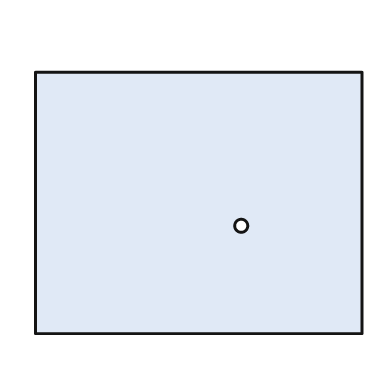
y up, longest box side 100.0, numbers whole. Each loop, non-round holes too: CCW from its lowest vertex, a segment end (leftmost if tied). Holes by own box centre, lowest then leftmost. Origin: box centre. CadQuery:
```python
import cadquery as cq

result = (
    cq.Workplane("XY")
    .moveTo(-50.0, -40.0)
    .lineTo(50.0, -40.0)
    .lineTo(50.0, 40.0)
    .lineTo(-50.0, 40.0)
    .close()
    .moveTo(13.0, -7.0)
    .circle(2.0)
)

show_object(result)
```